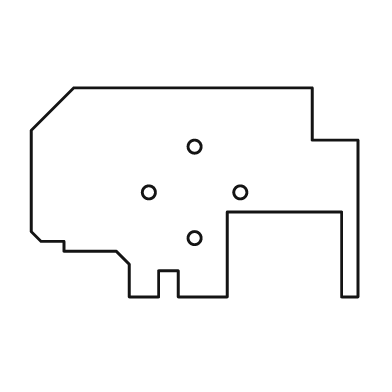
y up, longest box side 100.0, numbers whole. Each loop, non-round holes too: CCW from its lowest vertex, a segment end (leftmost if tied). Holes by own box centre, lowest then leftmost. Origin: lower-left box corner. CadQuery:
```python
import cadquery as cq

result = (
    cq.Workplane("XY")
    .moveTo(30.0, 0.0)
    .lineTo(39.0, 0.0)
    .lineTo(39.0, 8.0)
    .lineTo(45.0, 8.0)
    .lineTo(45.0, 0.0)
    .lineTo(60.0, 0.0)
    .lineTo(60.0, 26.0)
    .lineTo(95.0, 26.0)
    .lineTo(95.0, 0.0)
    .lineTo(100.0, 0.0)
    .lineTo(100.0, 48.0)
    .lineTo(86.0, 48.0)
    .lineTo(86.0, 64.0)
    .lineTo(13.0, 64.0)
    .lineTo(0.0, 51.0)
    .lineTo(0.0, 20.0)
    .lineTo(3.0, 17.0)
    .lineTo(10.0, 17.0)
    .lineTo(10.0, 14.0)
    .lineTo(26.0, 14.0)
    .lineTo(30.0, 10.0)
    .close()
    .moveTo(50.0, 18.0)
    .circle(2.0)
    .moveTo(36.0, 32.0)
    .circle(2.0)
    .moveTo(64.0, 32.0)
    .circle(2.0)
    .moveTo(50.0, 46.0)
    .circle(2.0)
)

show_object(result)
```